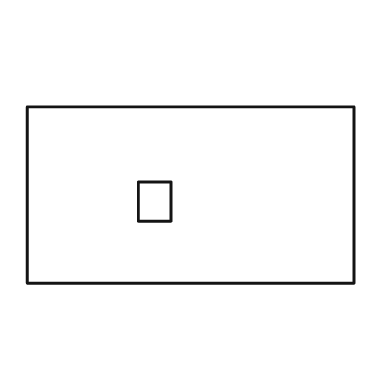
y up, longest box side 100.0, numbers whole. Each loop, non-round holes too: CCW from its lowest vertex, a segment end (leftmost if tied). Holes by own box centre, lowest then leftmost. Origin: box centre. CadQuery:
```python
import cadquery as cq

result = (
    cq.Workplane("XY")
    .moveTo(-50.0, -27.0)
    .lineTo(50.0, -27.0)
    .lineTo(50.0, 27.0)
    .lineTo(-50.0, 27.0)
    .close()
    .moveTo(-16.0, -8.0)
    .lineTo(-6.0, -8.0)
    .lineTo(-6.0, 4.0)
    .lineTo(-16.0, 4.0)
    .close()
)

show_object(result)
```